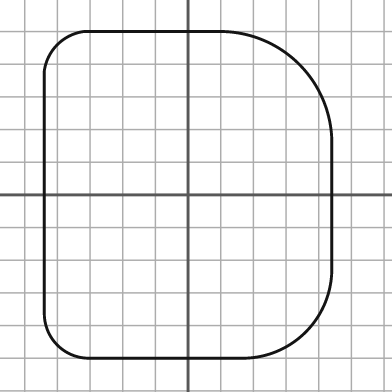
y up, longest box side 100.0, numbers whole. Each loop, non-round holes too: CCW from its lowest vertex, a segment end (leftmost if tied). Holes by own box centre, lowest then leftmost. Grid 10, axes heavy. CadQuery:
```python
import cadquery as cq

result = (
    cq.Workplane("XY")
    .moveTo(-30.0, -50.0)
    .lineTo(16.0, -50.0)
    .threePointArc((36.0, -42.0), (44.0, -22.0))
    .lineTo(44.0, 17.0)
    .threePointArc((34.0, 40.0), (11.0, 50.0))
    .lineTo(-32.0, 50.0)
    .threePointArc((-40.0, 46.0), (-44.0, 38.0))
    .lineTo(-44.0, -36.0)
    .threePointArc((-40.0, -46.0), (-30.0, -50.0))
    .close()
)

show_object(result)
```